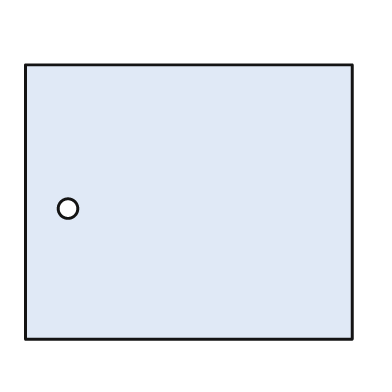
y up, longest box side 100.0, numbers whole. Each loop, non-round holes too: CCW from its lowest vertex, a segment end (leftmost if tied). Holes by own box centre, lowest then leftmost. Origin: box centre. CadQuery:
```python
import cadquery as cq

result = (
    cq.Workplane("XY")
    .moveTo(-50.0, -42.0)
    .lineTo(50.0, -42.0)
    .lineTo(50.0, 42.0)
    .lineTo(-50.0, 42.0)
    .close()
    .moveTo(-37.0, -2.0)
    .circle(3.0)
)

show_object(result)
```